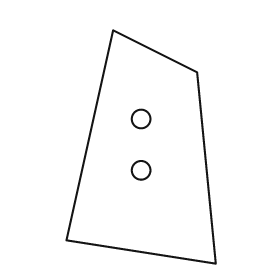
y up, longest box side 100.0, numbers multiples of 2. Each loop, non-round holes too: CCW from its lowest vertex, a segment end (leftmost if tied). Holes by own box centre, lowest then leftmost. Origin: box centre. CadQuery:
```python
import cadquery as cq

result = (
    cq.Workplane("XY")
    .moveTo(32.0, -50.0)
    .lineTo(24.0, 32.0)
    .lineTo(-12.0, 50.0)
    .lineTo(-32.0, -40.0)
    .close()
    .moveTo(0.0, -10.0)
    .circle(4.0)
    .moveTo(0.0, 12.0)
    .circle(4.0)
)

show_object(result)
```